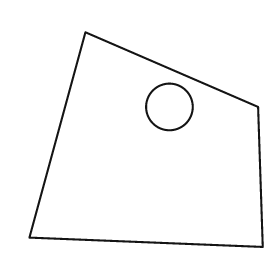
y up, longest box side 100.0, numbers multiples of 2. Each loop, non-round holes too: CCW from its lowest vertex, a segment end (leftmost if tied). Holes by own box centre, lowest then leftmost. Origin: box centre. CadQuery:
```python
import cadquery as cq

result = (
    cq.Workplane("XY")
    .moveTo(50.0, -46.0)
    .lineTo(48.0, 14.0)
    .lineTo(-26.0, 46.0)
    .lineTo(-50.0, -42.0)
    .close()
    .moveTo(10.0, 14.0)
    .circle(10.0)
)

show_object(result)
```